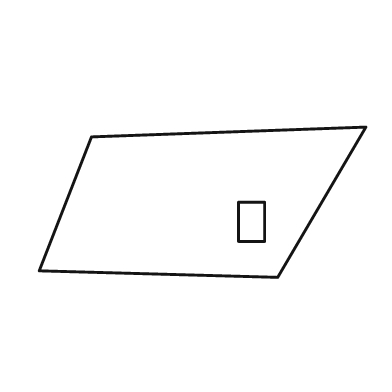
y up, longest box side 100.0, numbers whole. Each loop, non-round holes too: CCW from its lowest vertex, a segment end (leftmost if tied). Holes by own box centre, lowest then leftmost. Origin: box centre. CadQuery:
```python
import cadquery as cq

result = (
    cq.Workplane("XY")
    .moveTo(23.0, -23.0)
    .lineTo(50.0, 23.0)
    .lineTo(-34.0, 20.0)
    .lineTo(-50.0, -21.0)
    .close()
    .moveTo(11.0, -12.0)
    .lineTo(19.0, -12.0)
    .lineTo(19.0, 0.0)
    .lineTo(11.0, 0.0)
    .close()
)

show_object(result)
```